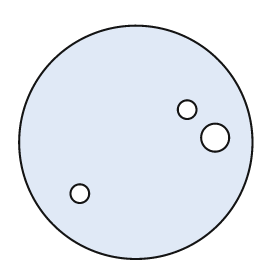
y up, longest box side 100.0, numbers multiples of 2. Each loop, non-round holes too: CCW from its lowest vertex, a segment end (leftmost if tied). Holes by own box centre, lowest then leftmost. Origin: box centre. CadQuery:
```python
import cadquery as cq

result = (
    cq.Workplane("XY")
    .moveTo(0.0, 0.0)
    .circle(50.0)
    .moveTo(-24.0, -22.0)
    .circle(4.0)
    .moveTo(34.0, 2.0)
    .circle(6.0)
    .moveTo(22.0, 14.0)
    .circle(4.0)
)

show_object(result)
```